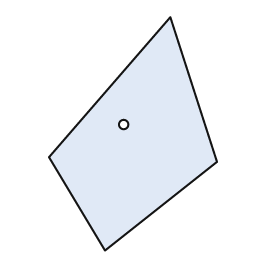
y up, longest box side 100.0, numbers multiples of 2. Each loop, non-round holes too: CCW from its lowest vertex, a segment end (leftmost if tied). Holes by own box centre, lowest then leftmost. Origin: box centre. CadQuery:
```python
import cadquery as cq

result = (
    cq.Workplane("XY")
    .moveTo(-12.0, -50.0)
    .lineTo(36.0, -12.0)
    .lineTo(16.0, 50.0)
    .lineTo(-36.0, -10.0)
    .close()
    .moveTo(-4.0, 4.0)
    .circle(2.0)
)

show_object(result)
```